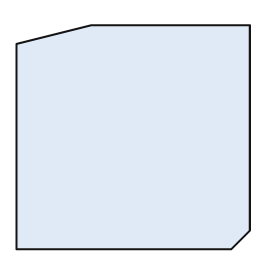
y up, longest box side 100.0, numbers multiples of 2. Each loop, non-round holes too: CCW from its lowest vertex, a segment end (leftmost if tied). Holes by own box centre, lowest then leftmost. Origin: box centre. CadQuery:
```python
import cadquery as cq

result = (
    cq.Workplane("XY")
    .moveTo(-50.0, -48.0)
    .lineTo(42.0, -48.0)
    .lineTo(50.0, -40.0)
    .lineTo(50.0, 48.0)
    .lineTo(-18.0, 48.0)
    .lineTo(-50.0, 40.0)
    .close()
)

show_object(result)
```